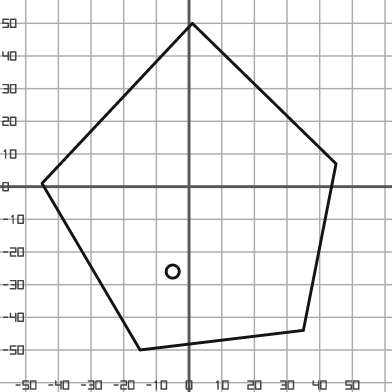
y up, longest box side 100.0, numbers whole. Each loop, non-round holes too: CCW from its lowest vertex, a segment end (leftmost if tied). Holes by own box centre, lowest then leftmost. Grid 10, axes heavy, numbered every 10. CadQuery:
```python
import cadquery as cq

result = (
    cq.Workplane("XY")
    .moveTo(-15.0, -50.0)
    .lineTo(35.0, -44.0)
    .lineTo(45.0, 7.0)
    .lineTo(1.0, 50.0)
    .lineTo(-45.0, 1.0)
    .close()
    .moveTo(-5.0, -26.0)
    .circle(2.0)
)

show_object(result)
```